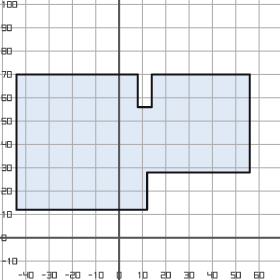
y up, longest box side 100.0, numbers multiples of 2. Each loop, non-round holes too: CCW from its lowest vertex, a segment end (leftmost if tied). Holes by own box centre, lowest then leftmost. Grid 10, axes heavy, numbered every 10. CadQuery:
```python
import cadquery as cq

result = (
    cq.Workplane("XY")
    .moveTo(-44.0, 12.0)
    .lineTo(12.0, 12.0)
    .lineTo(12.0, 28.0)
    .lineTo(56.0, 28.0)
    .lineTo(56.0, 70.0)
    .lineTo(14.0, 70.0)
    .lineTo(14.0, 56.0)
    .lineTo(8.0, 56.0)
    .lineTo(8.0, 70.0)
    .lineTo(-44.0, 70.0)
    .close()
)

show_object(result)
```